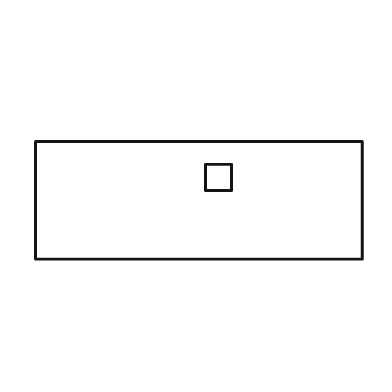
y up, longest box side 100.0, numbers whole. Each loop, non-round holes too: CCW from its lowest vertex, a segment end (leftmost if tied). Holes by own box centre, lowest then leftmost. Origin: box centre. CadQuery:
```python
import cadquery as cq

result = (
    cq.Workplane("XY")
    .moveTo(-50.0, -18.0)
    .lineTo(50.0, -18.0)
    .lineTo(50.0, 18.0)
    .lineTo(-50.0, 18.0)
    .close()
    .moveTo(2.0, 3.0)
    .lineTo(10.0, 3.0)
    .lineTo(10.0, 11.0)
    .lineTo(2.0, 11.0)
    .close()
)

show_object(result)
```